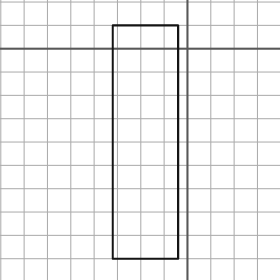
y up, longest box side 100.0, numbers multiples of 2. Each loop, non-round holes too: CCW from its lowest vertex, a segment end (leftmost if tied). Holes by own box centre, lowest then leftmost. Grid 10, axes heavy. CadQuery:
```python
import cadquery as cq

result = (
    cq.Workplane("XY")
    .moveTo(-32.0, -90.0)
    .lineTo(-4.0, -90.0)
    .lineTo(-4.0, 10.0)
    .lineTo(-32.0, 10.0)
    .close()
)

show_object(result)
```